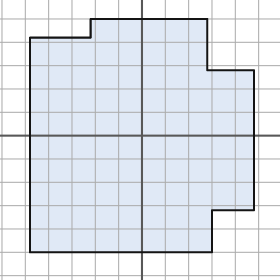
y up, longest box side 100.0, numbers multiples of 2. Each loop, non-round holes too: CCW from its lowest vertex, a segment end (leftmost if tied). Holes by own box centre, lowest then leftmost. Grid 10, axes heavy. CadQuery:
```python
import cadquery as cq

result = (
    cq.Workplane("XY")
    .moveTo(-48.0, -50.0)
    .lineTo(30.0, -50.0)
    .lineTo(30.0, -32.0)
    .lineTo(48.0, -32.0)
    .lineTo(48.0, 28.0)
    .lineTo(28.0, 28.0)
    .lineTo(28.0, 50.0)
    .lineTo(-22.0, 50.0)
    .lineTo(-22.0, 42.0)
    .lineTo(-48.0, 42.0)
    .close()
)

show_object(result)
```